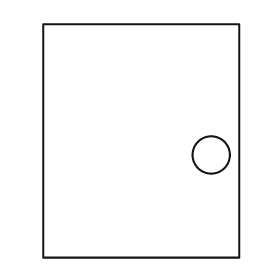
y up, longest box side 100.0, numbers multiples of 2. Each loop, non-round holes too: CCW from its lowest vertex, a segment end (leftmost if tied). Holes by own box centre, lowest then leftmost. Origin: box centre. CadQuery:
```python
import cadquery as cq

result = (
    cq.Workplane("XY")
    .moveTo(-42.0, -50.0)
    .lineTo(42.0, -50.0)
    .lineTo(42.0, 50.0)
    .lineTo(-42.0, 50.0)
    .close()
    .moveTo(30.0, -6.0)
    .circle(8.0)
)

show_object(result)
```